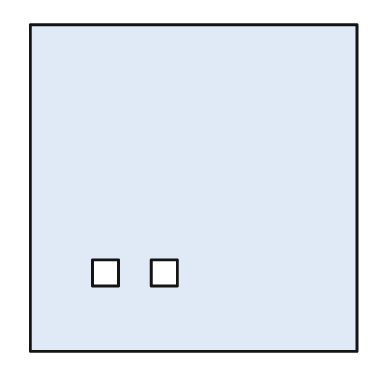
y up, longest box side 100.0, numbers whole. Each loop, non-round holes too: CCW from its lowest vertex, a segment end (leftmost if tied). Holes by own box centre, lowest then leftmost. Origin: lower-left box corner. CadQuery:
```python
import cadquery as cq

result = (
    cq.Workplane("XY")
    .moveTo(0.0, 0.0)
    .lineTo(100.0, 0.0)
    .lineTo(100.0, 100.0)
    .lineTo(0.0, 100.0)
    .close()
    .moveTo(19.0, 20.0)
    .lineTo(27.0, 20.0)
    .lineTo(27.0, 28.0)
    .lineTo(19.0, 28.0)
    .close()
    .moveTo(37.0, 20.0)
    .lineTo(45.0, 20.0)
    .lineTo(45.0, 28.0)
    .lineTo(37.0, 28.0)
    .close()
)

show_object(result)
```